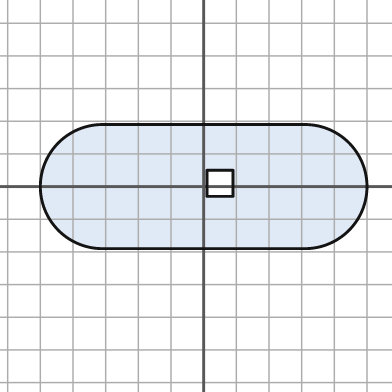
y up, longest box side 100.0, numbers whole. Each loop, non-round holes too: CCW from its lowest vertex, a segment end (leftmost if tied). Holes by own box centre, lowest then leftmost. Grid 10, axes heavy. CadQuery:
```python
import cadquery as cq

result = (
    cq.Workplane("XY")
    .moveTo(-31.0, -19.0)
    .lineTo(31.0, -19.0)
    .threePointArc((50.0, 0.0), (31.0, 19.0))
    .lineTo(-31.0, 19.0)
    .threePointArc((-50.0, 0.0), (-31.0, -19.0))
    .close()
    .moveTo(1.0, -3.0)
    .lineTo(9.0, -3.0)
    .lineTo(9.0, 5.0)
    .lineTo(1.0, 5.0)
    .close()
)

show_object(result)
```